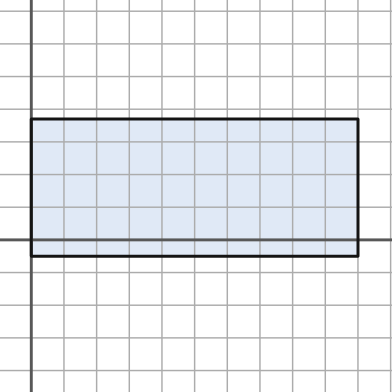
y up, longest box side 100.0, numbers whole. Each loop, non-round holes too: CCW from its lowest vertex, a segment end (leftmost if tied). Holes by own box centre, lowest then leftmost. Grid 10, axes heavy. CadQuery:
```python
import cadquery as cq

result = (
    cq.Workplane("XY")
    .moveTo(0.0, -5.0)
    .lineTo(100.0, -5.0)
    .lineTo(100.0, 37.0)
    .lineTo(0.0, 37.0)
    .close()
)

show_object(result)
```